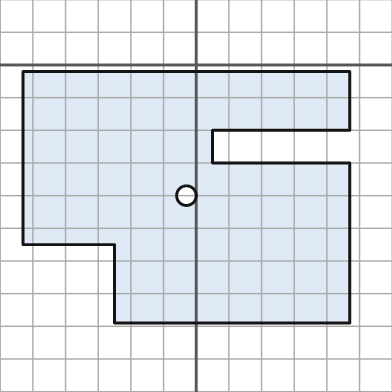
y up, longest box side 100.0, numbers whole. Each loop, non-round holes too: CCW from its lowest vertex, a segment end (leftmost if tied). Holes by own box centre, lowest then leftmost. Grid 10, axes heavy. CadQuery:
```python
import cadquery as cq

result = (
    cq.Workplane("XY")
    .moveTo(-25.0, -79.0)
    .lineTo(47.0, -79.0)
    .lineTo(47.0, -30.0)
    .lineTo(5.0, -30.0)
    .lineTo(5.0, -20.0)
    .lineTo(47.0, -20.0)
    .lineTo(47.0, -2.0)
    .lineTo(-53.0, -2.0)
    .lineTo(-53.0, -55.0)
    .lineTo(-25.0, -55.0)
    .close()
    .moveTo(-3.0, -40.0)
    .circle(3.0)
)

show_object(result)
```